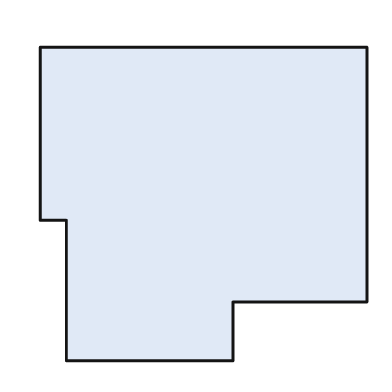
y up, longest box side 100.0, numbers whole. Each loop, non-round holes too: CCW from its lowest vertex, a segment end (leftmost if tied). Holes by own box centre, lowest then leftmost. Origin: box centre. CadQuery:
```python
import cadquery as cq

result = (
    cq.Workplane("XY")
    .moveTo(-42.0, -48.0)
    .lineTo(9.0, -48.0)
    .lineTo(9.0, -30.0)
    .lineTo(50.0, -30.0)
    .lineTo(50.0, 48.0)
    .lineTo(-50.0, 48.0)
    .lineTo(-50.0, -5.0)
    .lineTo(-42.0, -5.0)
    .close()
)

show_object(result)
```